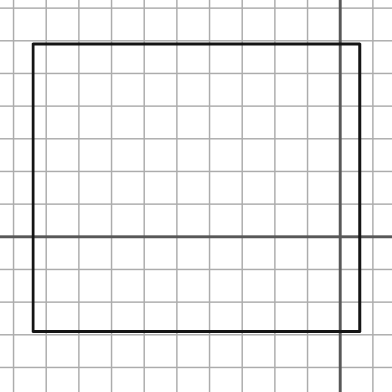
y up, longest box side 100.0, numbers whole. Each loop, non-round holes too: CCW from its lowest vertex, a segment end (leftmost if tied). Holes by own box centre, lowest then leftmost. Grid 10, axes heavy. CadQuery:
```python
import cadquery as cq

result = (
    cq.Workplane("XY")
    .moveTo(-94.0, -29.0)
    .lineTo(6.0, -29.0)
    .lineTo(6.0, 59.0)
    .lineTo(-94.0, 59.0)
    .close()
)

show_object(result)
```